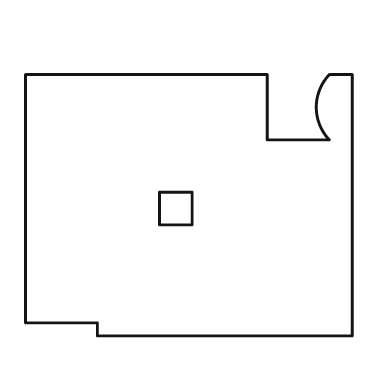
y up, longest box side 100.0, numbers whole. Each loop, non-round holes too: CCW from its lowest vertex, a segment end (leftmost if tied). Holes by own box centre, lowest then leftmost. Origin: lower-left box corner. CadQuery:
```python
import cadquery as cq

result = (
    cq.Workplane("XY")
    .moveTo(22.0, 0.0)
    .lineTo(100.0, 0.0)
    .lineTo(100.0, 80.0)
    .lineTo(93.0, 80.0)
    .threePointArc((89.0, 70.0), (93.0, 60.0))
    .lineTo(74.0, 60.0)
    .lineTo(74.0, 80.0)
    .lineTo(0.0, 80.0)
    .lineTo(0.0, 4.0)
    .lineTo(22.0, 4.0)
    .close()
    .moveTo(41.0, 34.0)
    .lineTo(51.0, 34.0)
    .lineTo(51.0, 44.0)
    .lineTo(41.0, 44.0)
    .close()
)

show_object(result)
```